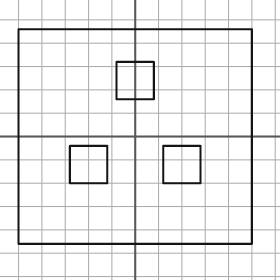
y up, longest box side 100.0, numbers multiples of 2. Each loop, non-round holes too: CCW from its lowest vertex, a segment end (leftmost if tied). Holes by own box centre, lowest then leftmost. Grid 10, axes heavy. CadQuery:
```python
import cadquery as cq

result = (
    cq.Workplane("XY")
    .moveTo(-50.0, -46.0)
    .lineTo(50.0, -46.0)
    .lineTo(50.0, 46.0)
    .lineTo(-50.0, 46.0)
    .close()
    .moveTo(-28.0, -20.0)
    .lineTo(-12.0, -20.0)
    .lineTo(-12.0, -4.0)
    .lineTo(-28.0, -4.0)
    .close()
    .moveTo(12.0, -20.0)
    .lineTo(28.0, -20.0)
    .lineTo(28.0, -4.0)
    .lineTo(12.0, -4.0)
    .close()
    .moveTo(-8.0, 16.0)
    .lineTo(8.0, 16.0)
    .lineTo(8.0, 32.0)
    .lineTo(-8.0, 32.0)
    .close()
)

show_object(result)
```